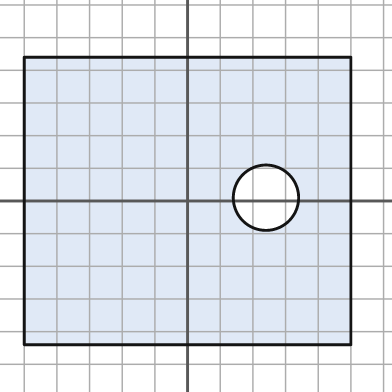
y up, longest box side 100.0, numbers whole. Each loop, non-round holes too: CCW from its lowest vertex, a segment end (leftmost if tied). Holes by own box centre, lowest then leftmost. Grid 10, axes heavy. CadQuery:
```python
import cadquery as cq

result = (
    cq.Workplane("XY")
    .moveTo(-50.0, -44.0)
    .lineTo(50.0, -44.0)
    .lineTo(50.0, 44.0)
    .lineTo(-50.0, 44.0)
    .close()
    .moveTo(24.0, 1.0)
    .circle(10.0)
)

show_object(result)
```